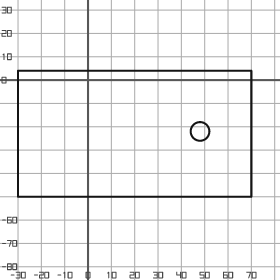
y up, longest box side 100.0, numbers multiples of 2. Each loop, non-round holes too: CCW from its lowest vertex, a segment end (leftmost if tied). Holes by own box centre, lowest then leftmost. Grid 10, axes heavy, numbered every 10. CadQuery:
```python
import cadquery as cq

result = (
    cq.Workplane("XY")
    .moveTo(-30.0, -50.0)
    .lineTo(70.0, -50.0)
    .lineTo(70.0, 4.0)
    .lineTo(-30.0, 4.0)
    .close()
    .moveTo(48.0, -22.0)
    .circle(4.0)
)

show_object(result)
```